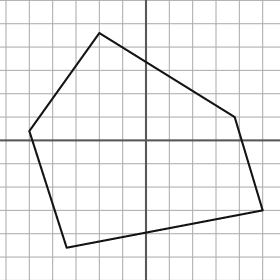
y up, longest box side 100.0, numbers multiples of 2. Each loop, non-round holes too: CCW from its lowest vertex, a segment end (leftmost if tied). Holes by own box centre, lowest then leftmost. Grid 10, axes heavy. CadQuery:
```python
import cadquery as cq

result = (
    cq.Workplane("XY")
    .moveTo(-34.0, -46.0)
    .lineTo(50.0, -30.0)
    .lineTo(38.0, 10.0)
    .lineTo(-20.0, 46.0)
    .lineTo(-50.0, 4.0)
    .close()
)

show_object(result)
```